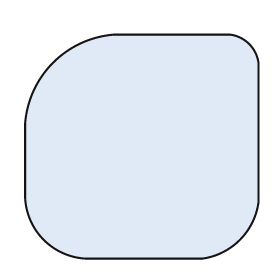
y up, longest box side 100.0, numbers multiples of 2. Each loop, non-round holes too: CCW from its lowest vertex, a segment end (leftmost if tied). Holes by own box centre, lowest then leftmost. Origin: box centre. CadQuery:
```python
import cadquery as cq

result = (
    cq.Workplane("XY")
    .moveTo(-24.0, -48.0)
    .lineTo(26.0, -48.0)
    .threePointArc((42.0, -40.0), (50.0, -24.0))
    .lineTo(50.0, 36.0)
    .threePointArc((46.0, 44.0), (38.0, 48.0))
    .lineTo(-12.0, 48.0)
    .threePointArc((-38.0, 36.0), (-50.0, 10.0))
    .lineTo(-50.0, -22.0)
    .threePointArc((-42.0, -40.0), (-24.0, -48.0))
    .close()
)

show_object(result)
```